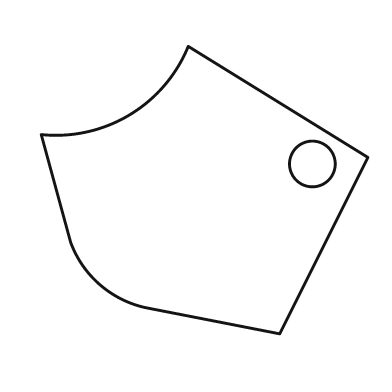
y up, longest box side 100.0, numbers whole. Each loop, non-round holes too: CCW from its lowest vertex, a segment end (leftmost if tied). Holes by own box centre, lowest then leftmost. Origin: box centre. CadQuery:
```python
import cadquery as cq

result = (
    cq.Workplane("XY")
    .moveTo(23.0, -44.0)
    .lineTo(50.0, 10.0)
    .lineTo(-5.0, 44.0)
    .threePointArc((-23.0, 23.0), (-50.0, 17.0))
    .lineTo(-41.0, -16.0)
    .threePointArc((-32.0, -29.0), (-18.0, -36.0))
    .close()
    .moveTo(33.0, 8.0)
    .circle(7.0)
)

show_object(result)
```